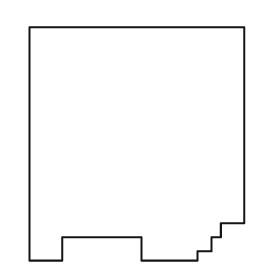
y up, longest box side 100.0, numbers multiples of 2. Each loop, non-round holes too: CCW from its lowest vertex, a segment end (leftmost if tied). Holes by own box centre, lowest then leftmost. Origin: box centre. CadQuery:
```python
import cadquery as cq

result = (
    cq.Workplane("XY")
    .moveTo(-46.0, -50.0)
    .lineTo(-32.0, -50.0)
    .lineTo(-32.0, -40.0)
    .lineTo(2.0, -40.0)
    .lineTo(2.0, -50.0)
    .lineTo(26.0, -50.0)
    .lineTo(26.0, -46.0)
    .lineTo(32.0, -46.0)
    .lineTo(32.0, -40.0)
    .lineTo(36.0, -40.0)
    .lineTo(36.0, -34.0)
    .lineTo(46.0, -34.0)
    .lineTo(46.0, 50.0)
    .lineTo(-46.0, 50.0)
    .close()
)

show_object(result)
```